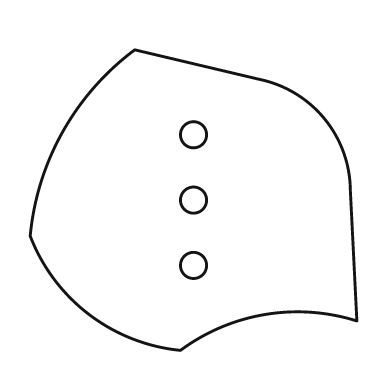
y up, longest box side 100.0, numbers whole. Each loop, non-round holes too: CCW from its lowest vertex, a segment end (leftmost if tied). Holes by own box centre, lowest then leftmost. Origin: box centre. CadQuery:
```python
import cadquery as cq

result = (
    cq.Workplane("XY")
    .moveTo(-4.0, -46.0)
    .threePointArc((22.0, -35.0), (50.0, -37.0))
    .lineTo(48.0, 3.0)
    .threePointArc((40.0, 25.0), (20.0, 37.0))
    .lineTo(-18.0, 46.0)
    .threePointArc((-40.0, 21.0), (-50.0, -11.0))
    .threePointArc((-32.0, -35.0), (-4.0, -46.0))
    .close()
    .moveTo(0.0, -20.0)
    .circle(4.0)
    .moveTo(0.0, 0.0)
    .circle(4.0)
    .moveTo(0.0, 20.0)
    .circle(4.0)
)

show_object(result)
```